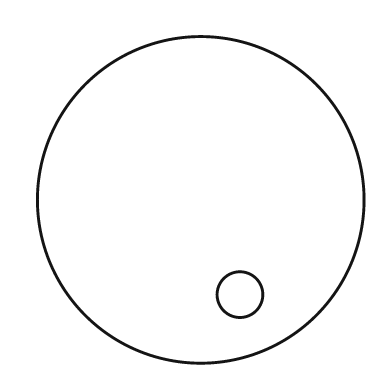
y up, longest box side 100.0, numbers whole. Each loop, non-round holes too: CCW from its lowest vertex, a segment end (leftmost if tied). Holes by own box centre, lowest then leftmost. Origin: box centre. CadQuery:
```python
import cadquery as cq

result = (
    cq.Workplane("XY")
    .moveTo(0.0, 0.0)
    .circle(50.0)
    .moveTo(12.0, -29.0)
    .circle(7.0)
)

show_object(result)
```